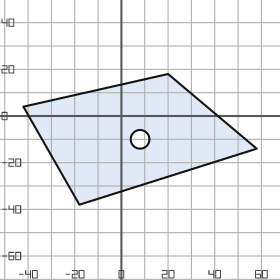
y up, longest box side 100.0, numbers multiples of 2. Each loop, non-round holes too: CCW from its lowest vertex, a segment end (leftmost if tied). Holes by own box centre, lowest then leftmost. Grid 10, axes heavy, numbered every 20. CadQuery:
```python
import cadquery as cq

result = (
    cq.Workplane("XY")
    .moveTo(-18.0, -38.0)
    .lineTo(58.0, -14.0)
    .lineTo(20.0, 18.0)
    .lineTo(-42.0, 4.0)
    .close()
    .moveTo(8.0, -10.0)
    .circle(4.0)
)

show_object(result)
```